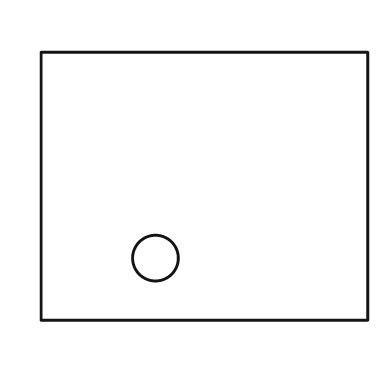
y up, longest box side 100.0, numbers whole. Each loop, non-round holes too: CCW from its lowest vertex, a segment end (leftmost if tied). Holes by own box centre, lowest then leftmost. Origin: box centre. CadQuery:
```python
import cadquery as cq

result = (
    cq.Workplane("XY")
    .moveTo(-50.0, -41.0)
    .lineTo(50.0, -41.0)
    .lineTo(50.0, 41.0)
    .lineTo(-50.0, 41.0)
    .close()
    .moveTo(-15.0, -22.0)
    .circle(7.0)
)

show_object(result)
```